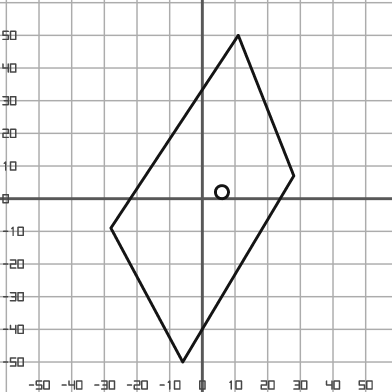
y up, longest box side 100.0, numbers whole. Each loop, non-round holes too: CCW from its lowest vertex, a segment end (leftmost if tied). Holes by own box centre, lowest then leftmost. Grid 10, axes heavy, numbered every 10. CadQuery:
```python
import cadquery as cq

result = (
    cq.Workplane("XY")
    .moveTo(-6.0, -50.0)
    .lineTo(28.0, 7.0)
    .lineTo(11.0, 50.0)
    .lineTo(-28.0, -9.0)
    .close()
    .moveTo(6.0, 2.0)
    .circle(2.0)
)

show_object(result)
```